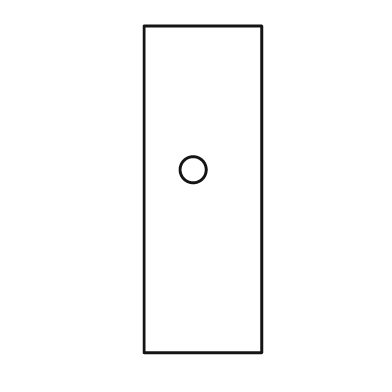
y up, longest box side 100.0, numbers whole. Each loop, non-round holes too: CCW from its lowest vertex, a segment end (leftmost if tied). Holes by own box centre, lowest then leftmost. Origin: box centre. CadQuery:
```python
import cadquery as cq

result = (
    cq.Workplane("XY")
    .moveTo(-18.0, -50.0)
    .lineTo(18.0, -50.0)
    .lineTo(18.0, 50.0)
    .lineTo(-18.0, 50.0)
    .close()
    .moveTo(-3.0, 6.0)
    .circle(4.0)
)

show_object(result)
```